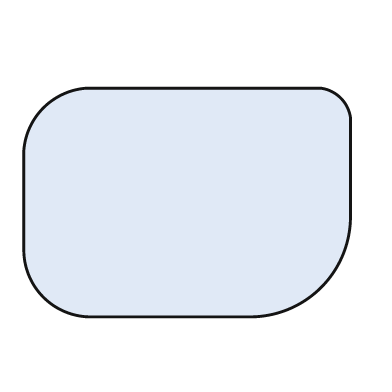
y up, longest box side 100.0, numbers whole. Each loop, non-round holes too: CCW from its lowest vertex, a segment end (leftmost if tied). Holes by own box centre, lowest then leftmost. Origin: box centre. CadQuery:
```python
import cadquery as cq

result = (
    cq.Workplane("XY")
    .moveTo(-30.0, -35.0)
    .lineTo(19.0, -35.0)
    .threePointArc((41.0, -26.0), (50.0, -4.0))
    .lineTo(50.0, 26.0)
    .threePointArc((47.0, 32.0), (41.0, 35.0))
    .lineTo(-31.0, 35.0)
    .threePointArc((-44.0, 29.0), (-50.0, 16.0))
    .lineTo(-50.0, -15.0)
    .threePointArc((-44.0, -29.0), (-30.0, -35.0))
    .close()
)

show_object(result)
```